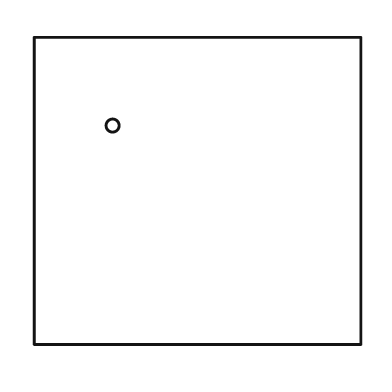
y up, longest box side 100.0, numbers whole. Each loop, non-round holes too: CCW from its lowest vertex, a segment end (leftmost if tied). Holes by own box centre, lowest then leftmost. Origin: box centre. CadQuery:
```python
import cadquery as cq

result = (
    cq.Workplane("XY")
    .moveTo(-50.0, -47.0)
    .lineTo(50.0, -47.0)
    .lineTo(50.0, 47.0)
    .lineTo(-50.0, 47.0)
    .close()
    .moveTo(-26.0, 20.0)
    .circle(2.0)
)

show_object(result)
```